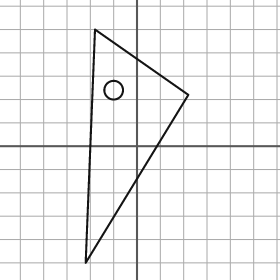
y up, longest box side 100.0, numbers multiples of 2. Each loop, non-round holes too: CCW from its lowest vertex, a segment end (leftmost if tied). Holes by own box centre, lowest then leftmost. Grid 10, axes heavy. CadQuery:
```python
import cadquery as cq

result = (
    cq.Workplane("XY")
    .moveTo(-22.0, -50.0)
    .lineTo(22.0, 22.0)
    .lineTo(-18.0, 50.0)
    .close()
    .moveTo(-10.0, 24.0)
    .circle(4.0)
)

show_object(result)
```